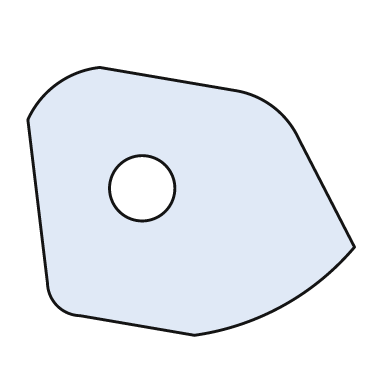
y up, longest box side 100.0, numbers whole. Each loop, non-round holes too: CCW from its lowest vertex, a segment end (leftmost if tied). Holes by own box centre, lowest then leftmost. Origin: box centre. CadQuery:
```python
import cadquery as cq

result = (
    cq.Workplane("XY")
    .moveTo(1.0, -41.0)
    .threePointArc((28.0, -32.0), (50.0, -14.0))
    .lineTo(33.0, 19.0)
    .threePointArc((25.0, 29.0), (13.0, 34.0))
    .lineTo(-28.0, 41.0)
    .threePointArc((-41.0, 36.0), (-50.0, 25.0))
    .lineTo(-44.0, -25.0)
    .threePointArc((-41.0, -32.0), (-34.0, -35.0))
    .close()
    .moveTo(-15.0, 4.0)
    .circle(10.0)
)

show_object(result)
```